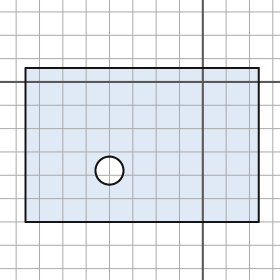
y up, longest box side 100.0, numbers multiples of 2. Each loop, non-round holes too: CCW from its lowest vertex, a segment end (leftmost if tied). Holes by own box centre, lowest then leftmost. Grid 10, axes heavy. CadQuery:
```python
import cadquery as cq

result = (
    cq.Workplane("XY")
    .moveTo(-76.0, -60.0)
    .lineTo(24.0, -60.0)
    .lineTo(24.0, 6.0)
    .lineTo(-76.0, 6.0)
    .close()
    .moveTo(-40.0, -38.0)
    .circle(6.0)
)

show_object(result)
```